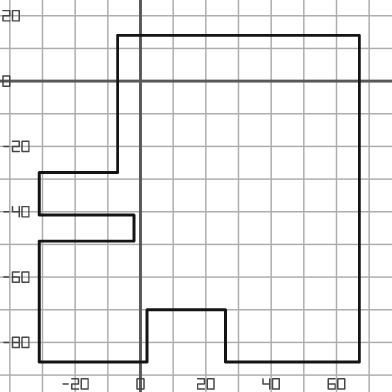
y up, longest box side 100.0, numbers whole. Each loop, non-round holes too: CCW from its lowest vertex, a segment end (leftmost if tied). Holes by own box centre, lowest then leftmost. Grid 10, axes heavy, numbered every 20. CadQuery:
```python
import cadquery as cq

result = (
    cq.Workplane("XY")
    .moveTo(-31.0, -86.0)
    .lineTo(2.0, -86.0)
    .lineTo(2.0, -70.0)
    .lineTo(26.0, -70.0)
    .lineTo(26.0, -86.0)
    .lineTo(67.0, -86.0)
    .lineTo(67.0, 14.0)
    .lineTo(-7.0, 14.0)
    .lineTo(-7.0, -28.0)
    .lineTo(-31.0, -28.0)
    .lineTo(-31.0, -41.0)
    .lineTo(-2.0, -41.0)
    .lineTo(-2.0, -49.0)
    .lineTo(-31.0, -49.0)
    .close()
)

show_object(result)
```